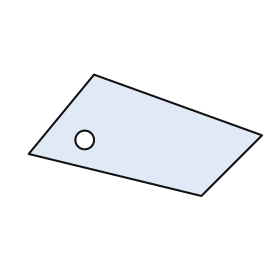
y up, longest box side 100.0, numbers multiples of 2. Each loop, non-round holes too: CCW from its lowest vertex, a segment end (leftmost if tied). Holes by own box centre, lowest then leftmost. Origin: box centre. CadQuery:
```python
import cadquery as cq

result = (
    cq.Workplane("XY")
    .moveTo(24.0, -26.0)
    .lineTo(50.0, 0.0)
    .lineTo(-22.0, 26.0)
    .lineTo(-50.0, -8.0)
    .close()
    .moveTo(-26.0, -2.0)
    .circle(4.0)
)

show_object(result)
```